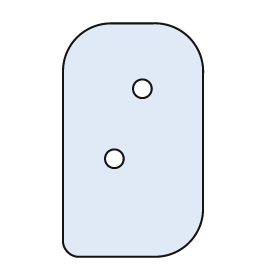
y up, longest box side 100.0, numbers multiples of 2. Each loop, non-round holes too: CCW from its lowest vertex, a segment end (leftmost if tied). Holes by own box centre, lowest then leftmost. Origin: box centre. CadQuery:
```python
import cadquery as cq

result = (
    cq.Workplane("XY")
    .moveTo(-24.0, -50.0)
    .lineTo(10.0, -50.0)
    .threePointArc((24.0, -44.0), (30.0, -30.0))
    .lineTo(30.0, 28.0)
    .threePointArc((24.0, 44.0), (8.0, 50.0))
    .lineTo(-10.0, 50.0)
    .threePointArc((-24.0, 44.0), (-30.0, 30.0))
    .lineTo(-30.0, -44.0)
    .threePointArc((-28.0, -48.0), (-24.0, -50.0))
    .close()
    .moveTo(-8.0, -8.0)
    .circle(4.0)
    .moveTo(4.0, 22.0)
    .circle(4.0)
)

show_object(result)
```